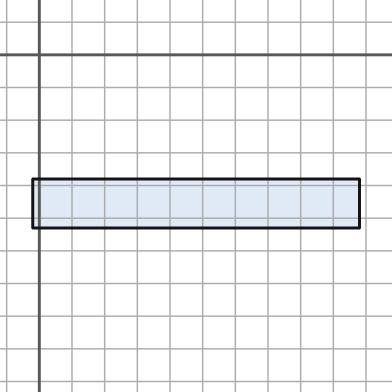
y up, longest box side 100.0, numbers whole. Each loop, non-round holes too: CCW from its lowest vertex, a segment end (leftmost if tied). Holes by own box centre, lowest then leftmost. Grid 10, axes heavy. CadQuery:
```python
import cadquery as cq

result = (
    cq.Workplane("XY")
    .moveTo(-2.0, -53.0)
    .lineTo(98.0, -53.0)
    .lineTo(98.0, -38.0)
    .lineTo(-2.0, -38.0)
    .close()
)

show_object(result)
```